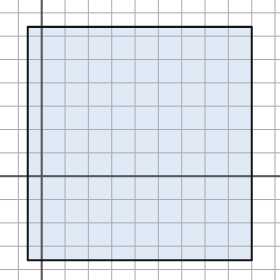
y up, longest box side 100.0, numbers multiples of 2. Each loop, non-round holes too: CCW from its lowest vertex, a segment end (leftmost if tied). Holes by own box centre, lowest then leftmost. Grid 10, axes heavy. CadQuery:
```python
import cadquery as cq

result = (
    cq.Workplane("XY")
    .moveTo(-6.0, -36.0)
    .lineTo(90.0, -36.0)
    .lineTo(90.0, 64.0)
    .lineTo(-6.0, 64.0)
    .close()
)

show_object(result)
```